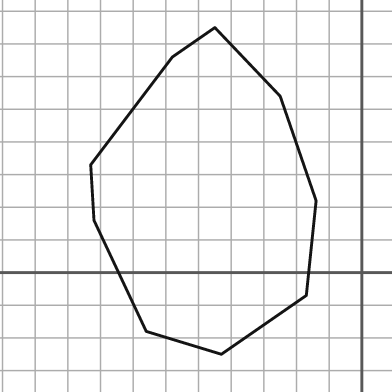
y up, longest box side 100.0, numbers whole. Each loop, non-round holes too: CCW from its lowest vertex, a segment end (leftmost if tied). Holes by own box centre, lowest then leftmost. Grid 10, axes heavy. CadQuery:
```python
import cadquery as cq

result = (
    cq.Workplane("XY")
    .moveTo(-43.0, -25.0)
    .lineTo(-17.0, -7.0)
    .lineTo(-14.0, 22.0)
    .lineTo(-25.0, 54.0)
    .lineTo(-45.0, 75.0)
    .lineTo(-58.0, 66.0)
    .lineTo(-83.0, 33.0)
    .lineTo(-82.0, 16.0)
    .lineTo(-66.0, -18.0)
    .close()
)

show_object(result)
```